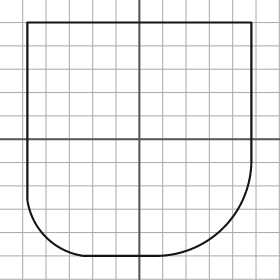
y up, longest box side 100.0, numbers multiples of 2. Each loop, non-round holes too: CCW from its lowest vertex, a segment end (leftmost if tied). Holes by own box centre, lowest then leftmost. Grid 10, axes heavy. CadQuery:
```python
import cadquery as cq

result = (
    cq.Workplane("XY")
    .moveTo(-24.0, -50.0)
    .lineTo(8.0, -50.0)
    .threePointArc((36.0, -38.0), (48.0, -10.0))
    .lineTo(48.0, 50.0)
    .lineTo(-48.0, 50.0)
    .lineTo(-48.0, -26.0)
    .threePointArc((-40.0, -42.0), (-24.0, -50.0))
    .close()
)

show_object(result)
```